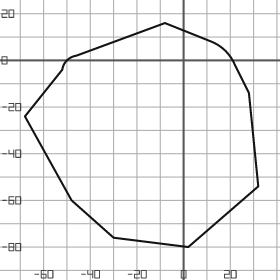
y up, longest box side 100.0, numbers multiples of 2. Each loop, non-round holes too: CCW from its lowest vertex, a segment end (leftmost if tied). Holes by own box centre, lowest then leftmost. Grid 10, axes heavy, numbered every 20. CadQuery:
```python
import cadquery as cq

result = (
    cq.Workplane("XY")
    .moveTo(2.0, -80.0)
    .lineTo(32.0, -54.0)
    .lineTo(28.0, -14.0)
    .lineTo(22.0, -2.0)
    .threePointArc((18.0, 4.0), (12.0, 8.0))
    .lineTo(-8.0, 16.0)
    .lineTo(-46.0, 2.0)
    .threePointArc((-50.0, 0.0), (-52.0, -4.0))
    .lineTo(-68.0, -24.0)
    .lineTo(-48.0, -60.0)
    .lineTo(-30.0, -76.0)
    .close()
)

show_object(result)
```